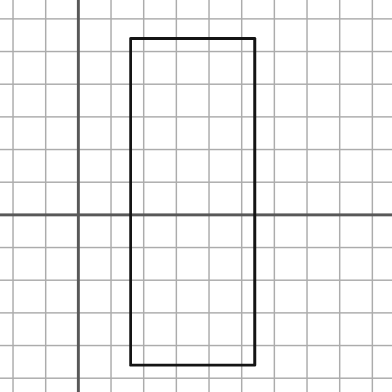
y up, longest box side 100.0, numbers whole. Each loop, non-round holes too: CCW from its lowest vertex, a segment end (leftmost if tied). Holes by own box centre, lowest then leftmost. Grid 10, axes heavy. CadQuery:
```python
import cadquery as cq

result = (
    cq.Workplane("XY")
    .moveTo(16.0, -46.0)
    .lineTo(54.0, -46.0)
    .lineTo(54.0, 54.0)
    .lineTo(16.0, 54.0)
    .close()
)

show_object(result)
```